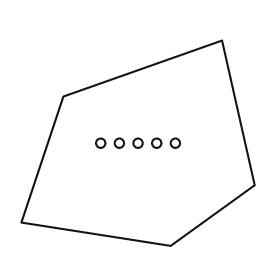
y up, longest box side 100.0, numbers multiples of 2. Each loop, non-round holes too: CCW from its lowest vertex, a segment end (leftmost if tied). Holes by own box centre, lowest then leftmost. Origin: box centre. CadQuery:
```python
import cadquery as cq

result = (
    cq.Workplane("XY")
    .moveTo(14.0, -44.0)
    .lineTo(50.0, -18.0)
    .lineTo(36.0, 44.0)
    .lineTo(-32.0, 20.0)
    .lineTo(-50.0, -34.0)
    .close()
    .moveTo(-16.0, 0.0)
    .circle(2.0)
    .moveTo(-8.0, 0.0)
    .circle(2.0)
    .moveTo(0.0, 0.0)
    .circle(2.0)
    .moveTo(8.0, 0.0)
    .circle(2.0)
    .moveTo(16.0, 0.0)
    .circle(2.0)
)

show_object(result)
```